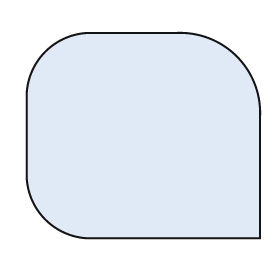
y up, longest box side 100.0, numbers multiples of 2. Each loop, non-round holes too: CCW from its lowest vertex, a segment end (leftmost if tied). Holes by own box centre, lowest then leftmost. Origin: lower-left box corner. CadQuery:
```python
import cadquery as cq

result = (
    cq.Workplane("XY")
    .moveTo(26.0, 0.0)
    .lineTo(100.0, 0.0)
    .lineTo(100.0, 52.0)
    .threePointArc((90.0, 78.0), (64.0, 88.0))
    .lineTo(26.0, 88.0)
    .threePointArc((8.0, 80.0), (0.0, 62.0))
    .lineTo(0.0, 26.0)
    .threePointArc((8.0, 8.0), (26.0, 0.0))
    .close()
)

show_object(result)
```